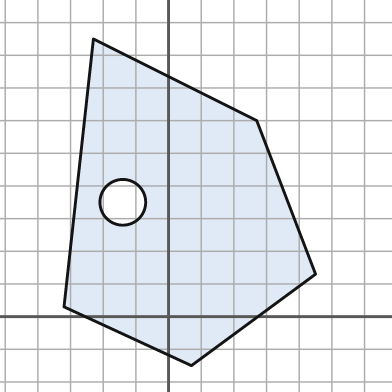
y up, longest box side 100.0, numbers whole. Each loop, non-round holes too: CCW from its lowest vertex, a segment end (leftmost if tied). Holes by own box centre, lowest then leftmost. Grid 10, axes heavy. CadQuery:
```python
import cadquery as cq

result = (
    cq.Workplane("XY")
    .moveTo(7.0, -15.0)
    .lineTo(45.0, 13.0)
    .lineTo(27.0, 60.0)
    .lineTo(-23.0, 85.0)
    .lineTo(-32.0, 3.0)
    .close()
    .moveTo(-14.0, 35.0)
    .circle(7.0)
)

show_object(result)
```